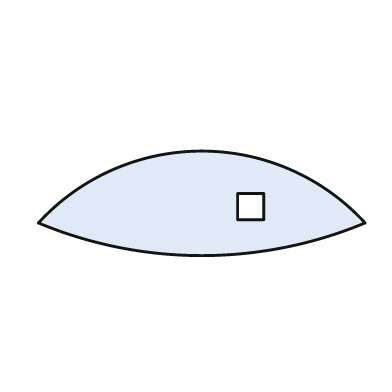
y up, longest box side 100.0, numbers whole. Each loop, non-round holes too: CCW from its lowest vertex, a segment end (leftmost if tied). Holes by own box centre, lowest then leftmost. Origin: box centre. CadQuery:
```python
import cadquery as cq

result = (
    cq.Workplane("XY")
    .moveTo(-50.0, -6.0)
    .threePointArc((0.0, -16.0), (50.0, -6.0))
    .threePointArc((0.0, 16.0), (-50.0, -6.0))
    .close()
    .moveTo(11.0, -5.0)
    .lineTo(19.0, -5.0)
    .lineTo(19.0, 3.0)
    .lineTo(11.0, 3.0)
    .close()
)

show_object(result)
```